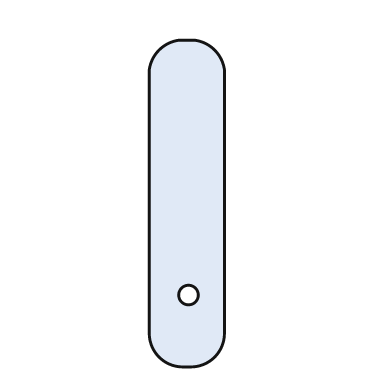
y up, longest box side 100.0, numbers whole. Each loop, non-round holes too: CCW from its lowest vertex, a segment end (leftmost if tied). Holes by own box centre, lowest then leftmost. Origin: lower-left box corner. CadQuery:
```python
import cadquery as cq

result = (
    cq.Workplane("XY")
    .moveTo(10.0, 0.0)
    .lineTo(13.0, 0.0)
    .threePointArc((20.0, 3.0), (23.0, 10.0))
    .lineTo(23.0, 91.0)
    .threePointArc((20.0, 97.0), (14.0, 100.0))
    .lineTo(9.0, 100.0)
    .threePointArc((3.0, 97.0), (0.0, 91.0))
    .lineTo(0.0, 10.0)
    .threePointArc((3.0, 3.0), (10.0, 0.0))
    .close()
    .moveTo(12.0, 22.0)
    .circle(3.0)
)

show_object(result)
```